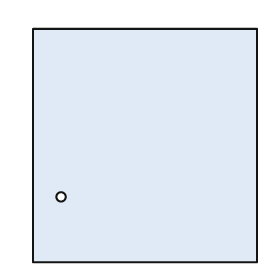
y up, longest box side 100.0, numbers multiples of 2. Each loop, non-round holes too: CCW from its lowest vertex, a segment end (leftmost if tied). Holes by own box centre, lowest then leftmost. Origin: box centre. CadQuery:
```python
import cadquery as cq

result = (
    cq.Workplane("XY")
    .moveTo(-48.0, -50.0)
    .lineTo(48.0, -50.0)
    .lineTo(48.0, 50.0)
    .lineTo(-48.0, 50.0)
    .close()
    .moveTo(-36.0, -22.0)
    .circle(2.0)
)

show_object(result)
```